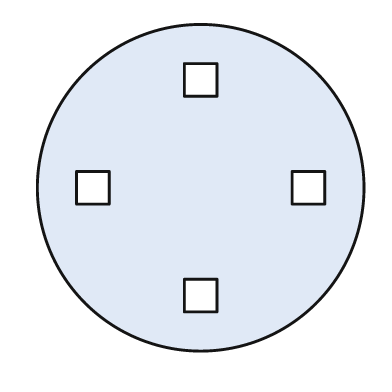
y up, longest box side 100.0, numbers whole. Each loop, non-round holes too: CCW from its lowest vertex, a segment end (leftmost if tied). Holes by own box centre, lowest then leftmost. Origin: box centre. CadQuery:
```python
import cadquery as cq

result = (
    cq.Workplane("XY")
    .moveTo(0.0, 0.0)
    .circle(50.0)
    .moveTo(-5.0, -38.0)
    .lineTo(5.0, -38.0)
    .lineTo(5.0, -28.0)
    .lineTo(-5.0, -28.0)
    .close()
    .moveTo(-38.0, -5.0)
    .lineTo(-28.0, -5.0)
    .lineTo(-28.0, 5.0)
    .lineTo(-38.0, 5.0)
    .close()
    .moveTo(28.0, -5.0)
    .lineTo(38.0, -5.0)
    .lineTo(38.0, 5.0)
    .lineTo(28.0, 5.0)
    .close()
    .moveTo(-5.0, 28.0)
    .lineTo(5.0, 28.0)
    .lineTo(5.0, 38.0)
    .lineTo(-5.0, 38.0)
    .close()
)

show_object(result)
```